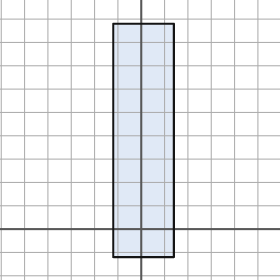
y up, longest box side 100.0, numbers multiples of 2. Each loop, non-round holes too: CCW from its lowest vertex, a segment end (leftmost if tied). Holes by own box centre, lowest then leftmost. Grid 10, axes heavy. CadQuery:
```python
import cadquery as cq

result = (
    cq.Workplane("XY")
    .moveTo(-12.0, -12.0)
    .lineTo(14.0, -12.0)
    .lineTo(14.0, 88.0)
    .lineTo(-12.0, 88.0)
    .close()
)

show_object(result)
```